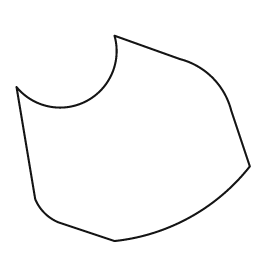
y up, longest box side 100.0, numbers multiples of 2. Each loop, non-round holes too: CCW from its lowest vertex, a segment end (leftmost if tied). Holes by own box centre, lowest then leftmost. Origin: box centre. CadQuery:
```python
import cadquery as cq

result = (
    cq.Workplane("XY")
    .moveTo(-8.0, -44.0)
    .threePointArc((24.0, -34.0), (50.0, -12.0))
    .lineTo(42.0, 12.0)
    .threePointArc((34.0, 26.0), (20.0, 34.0))
    .lineTo(-8.0, 44.0)
    .threePointArc((-20.0, 16.0), (-50.0, 22.0))
    .lineTo(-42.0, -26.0)
    .threePointArc((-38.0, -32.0), (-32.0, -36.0))
    .close()
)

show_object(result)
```